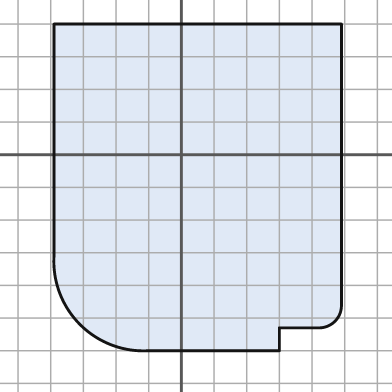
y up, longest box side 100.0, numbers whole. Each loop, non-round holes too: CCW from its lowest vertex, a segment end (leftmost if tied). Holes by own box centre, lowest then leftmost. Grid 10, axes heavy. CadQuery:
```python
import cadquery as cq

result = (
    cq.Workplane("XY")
    .moveTo(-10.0, -60.0)
    .lineTo(30.0, -60.0)
    .lineTo(30.0, -53.0)
    .lineTo(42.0, -53.0)
    .threePointArc((47.0, -51.0), (49.0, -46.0))
    .lineTo(49.0, 40.0)
    .lineTo(-39.0, 40.0)
    .lineTo(-39.0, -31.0)
    .threePointArc((-31.0, -52.0), (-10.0, -60.0))
    .close()
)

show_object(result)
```